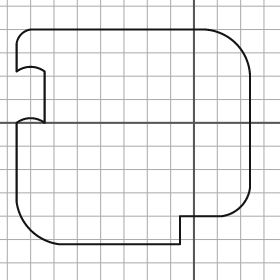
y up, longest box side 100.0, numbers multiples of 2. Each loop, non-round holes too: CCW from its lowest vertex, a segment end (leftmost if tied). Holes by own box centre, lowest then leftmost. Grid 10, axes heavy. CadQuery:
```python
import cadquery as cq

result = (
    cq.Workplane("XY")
    .moveTo(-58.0, -52.0)
    .lineTo(-6.0, -52.0)
    .lineTo(-6.0, -40.0)
    .lineTo(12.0, -40.0)
    .threePointArc((20.0, -36.0), (24.0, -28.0))
    .lineTo(24.0, 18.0)
    .threePointArc((18.0, 34.0), (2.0, 40.0))
    .lineTo(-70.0, 40.0)
    .threePointArc((-74.0, 38.0), (-76.0, 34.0))
    .lineTo(-76.0, 22.0)
    .threePointArc((-70.0, 24.0), (-64.0, 22.0))
    .lineTo(-64.0, 0.0)
    .threePointArc((-70.0, 2.0), (-76.0, 0.0))
    .lineTo(-76.0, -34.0)
    .threePointArc((-70.0, -46.0), (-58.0, -52.0))
    .close()
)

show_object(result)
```